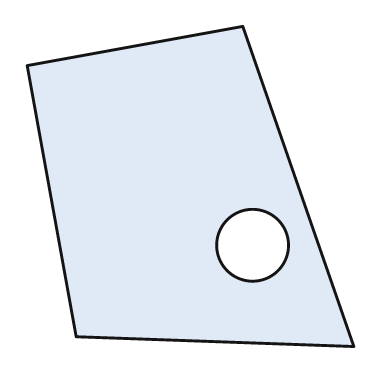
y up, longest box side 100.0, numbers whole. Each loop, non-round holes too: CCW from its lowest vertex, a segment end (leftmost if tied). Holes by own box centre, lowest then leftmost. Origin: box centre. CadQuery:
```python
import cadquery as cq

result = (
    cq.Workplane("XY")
    .moveTo(50.0, -49.0)
    .lineTo(16.0, 49.0)
    .lineTo(-50.0, 37.0)
    .lineTo(-35.0, -46.0)
    .close()
    .moveTo(19.0, -18.0)
    .circle(11.0)
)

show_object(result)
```